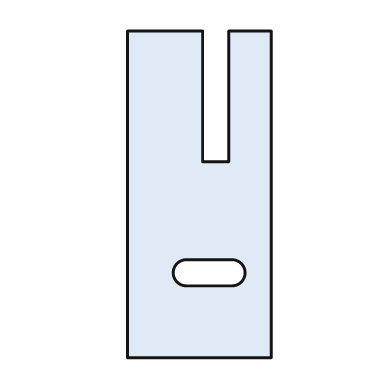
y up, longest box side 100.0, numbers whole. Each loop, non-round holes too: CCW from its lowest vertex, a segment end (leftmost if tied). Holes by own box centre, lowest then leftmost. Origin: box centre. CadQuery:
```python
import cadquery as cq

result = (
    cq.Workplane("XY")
    .moveTo(-22.0, -50.0)
    .lineTo(22.0, -50.0)
    .lineTo(22.0, 50.0)
    .lineTo(9.0, 50.0)
    .lineTo(9.0, 10.0)
    .lineTo(1.0, 10.0)
    .lineTo(1.0, 50.0)
    .lineTo(-22.0, 50.0)
    .close()
    .moveTo(-4.0, -28.0)
    .lineTo(10.0, -28.0)
    .threePointArc((14.0, -24.0), (10.0, -20.0))
    .lineTo(-4.0, -20.0)
    .threePointArc((-8.0, -24.0), (-4.0, -28.0))
    .close()
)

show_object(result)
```